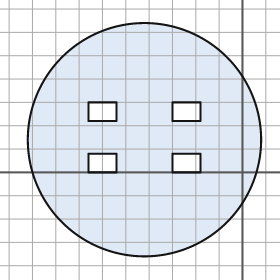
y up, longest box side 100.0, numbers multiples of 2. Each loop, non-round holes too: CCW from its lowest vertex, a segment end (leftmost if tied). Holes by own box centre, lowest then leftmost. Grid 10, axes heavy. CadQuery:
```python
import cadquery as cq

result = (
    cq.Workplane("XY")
    .moveTo(-42.0, 14.0)
    .circle(50.0)
    .moveTo(-66.0, 0.0)
    .lineTo(-54.0, 0.0)
    .lineTo(-54.0, 8.0)
    .lineTo(-66.0, 8.0)
    .close()
    .moveTo(-30.0, 0.0)
    .lineTo(-18.0, 0.0)
    .lineTo(-18.0, 8.0)
    .lineTo(-30.0, 8.0)
    .close()
    .moveTo(-66.0, 22.0)
    .lineTo(-54.0, 22.0)
    .lineTo(-54.0, 30.0)
    .lineTo(-66.0, 30.0)
    .close()
    .moveTo(-30.0, 22.0)
    .lineTo(-18.0, 22.0)
    .lineTo(-18.0, 30.0)
    .lineTo(-30.0, 30.0)
    .close()
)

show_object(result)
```